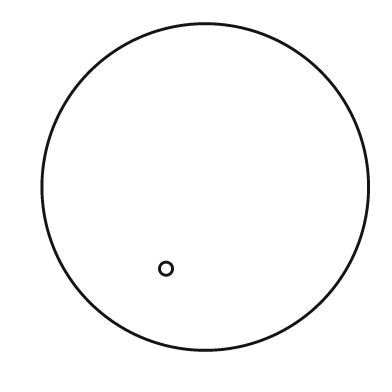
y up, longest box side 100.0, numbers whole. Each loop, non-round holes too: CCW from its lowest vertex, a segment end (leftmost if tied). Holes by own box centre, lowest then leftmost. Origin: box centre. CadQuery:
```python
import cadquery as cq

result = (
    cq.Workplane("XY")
    .moveTo(0.0, 0.0)
    .circle(50.0)
    .moveTo(-12.0, -25.0)
    .circle(2.0)
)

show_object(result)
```